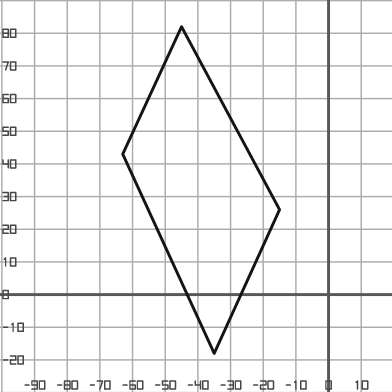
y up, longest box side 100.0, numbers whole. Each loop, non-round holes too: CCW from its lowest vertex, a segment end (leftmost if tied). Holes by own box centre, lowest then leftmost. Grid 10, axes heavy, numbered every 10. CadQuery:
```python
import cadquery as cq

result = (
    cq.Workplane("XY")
    .moveTo(-35.0, -18.0)
    .lineTo(-15.0, 26.0)
    .lineTo(-45.0, 82.0)
    .lineTo(-63.0, 43.0)
    .close()
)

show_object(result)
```